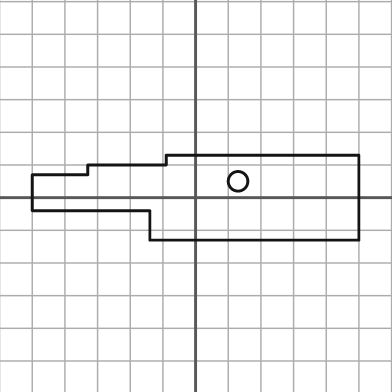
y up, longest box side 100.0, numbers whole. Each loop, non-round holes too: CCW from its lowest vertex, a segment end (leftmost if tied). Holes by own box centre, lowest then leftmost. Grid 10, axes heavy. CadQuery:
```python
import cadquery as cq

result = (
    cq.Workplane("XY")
    .moveTo(-14.0, -13.0)
    .lineTo(50.0, -13.0)
    .lineTo(50.0, 13.0)
    .lineTo(-9.0, 13.0)
    .lineTo(-9.0, 10.0)
    .lineTo(-33.0, 10.0)
    .lineTo(-33.0, 7.0)
    .lineTo(-50.0, 7.0)
    .lineTo(-50.0, -4.0)
    .lineTo(-14.0, -4.0)
    .close()
    .moveTo(13.0, 5.0)
    .circle(3.0)
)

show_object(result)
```